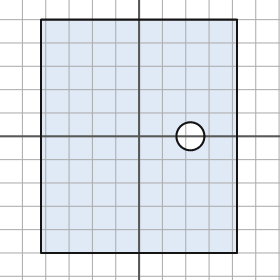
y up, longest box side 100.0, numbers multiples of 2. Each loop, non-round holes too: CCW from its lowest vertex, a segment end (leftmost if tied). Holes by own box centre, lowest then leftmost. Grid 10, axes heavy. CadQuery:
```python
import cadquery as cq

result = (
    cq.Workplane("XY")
    .moveTo(-42.0, -50.0)
    .lineTo(42.0, -50.0)
    .lineTo(42.0, 50.0)
    .lineTo(-42.0, 50.0)
    .close()
    .moveTo(22.0, 0.0)
    .circle(6.0)
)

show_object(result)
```